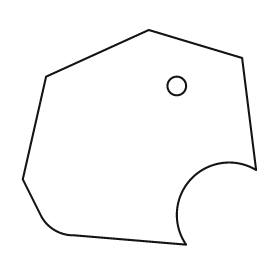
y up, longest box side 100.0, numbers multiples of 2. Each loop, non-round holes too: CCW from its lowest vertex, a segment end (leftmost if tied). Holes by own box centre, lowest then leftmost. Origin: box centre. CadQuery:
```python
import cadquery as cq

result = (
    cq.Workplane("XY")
    .moveTo(20.0, -46.0)
    .threePointArc((22.0, -18.0), (50.0, -14.0))
    .lineTo(44.0, 34.0)
    .lineTo(4.0, 46.0)
    .lineTo(-40.0, 26.0)
    .lineTo(-50.0, -18.0)
    .lineTo(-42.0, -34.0)
    .threePointArc((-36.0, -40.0), (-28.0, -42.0))
    .close()
    .moveTo(16.0, 22.0)
    .circle(4.0)
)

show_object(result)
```